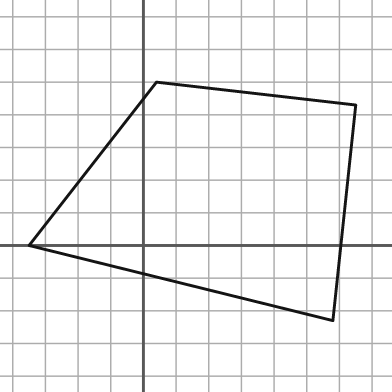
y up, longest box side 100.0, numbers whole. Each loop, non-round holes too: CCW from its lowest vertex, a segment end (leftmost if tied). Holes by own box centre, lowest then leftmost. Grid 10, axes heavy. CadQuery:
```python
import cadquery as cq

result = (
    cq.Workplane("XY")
    .moveTo(58.0, -23.0)
    .lineTo(65.0, 43.0)
    .lineTo(4.0, 50.0)
    .lineTo(-35.0, 0.0)
    .close()
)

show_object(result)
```